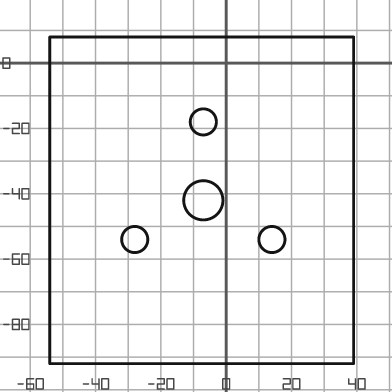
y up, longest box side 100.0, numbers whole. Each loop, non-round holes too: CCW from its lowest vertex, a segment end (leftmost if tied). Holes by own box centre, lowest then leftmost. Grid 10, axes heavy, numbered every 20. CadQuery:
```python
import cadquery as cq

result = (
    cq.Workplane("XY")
    .moveTo(-54.0, -92.0)
    .lineTo(39.0, -92.0)
    .lineTo(39.0, 8.0)
    .lineTo(-54.0, 8.0)
    .close()
    .moveTo(-28.0, -54.0)
    .circle(4.0)
    .moveTo(14.0, -54.0)
    .circle(4.0)
    .moveTo(-7.0, -42.0)
    .circle(6.0)
    .moveTo(-7.0, -18.0)
    .circle(4.0)
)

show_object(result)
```